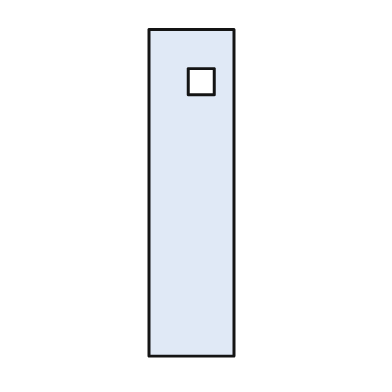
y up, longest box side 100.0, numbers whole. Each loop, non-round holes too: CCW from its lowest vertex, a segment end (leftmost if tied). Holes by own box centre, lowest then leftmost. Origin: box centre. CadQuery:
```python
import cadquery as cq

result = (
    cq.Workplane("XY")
    .moveTo(-13.0, -50.0)
    .lineTo(13.0, -50.0)
    .lineTo(13.0, 50.0)
    .lineTo(-13.0, 50.0)
    .close()
    .moveTo(-1.0, 30.0)
    .lineTo(7.0, 30.0)
    .lineTo(7.0, 38.0)
    .lineTo(-1.0, 38.0)
    .close()
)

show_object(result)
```